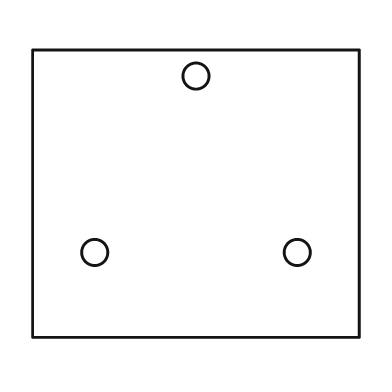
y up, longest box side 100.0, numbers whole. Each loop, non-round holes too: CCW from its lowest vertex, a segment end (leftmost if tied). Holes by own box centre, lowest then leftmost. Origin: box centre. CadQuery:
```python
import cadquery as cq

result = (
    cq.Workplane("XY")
    .moveTo(-50.0, -44.0)
    .lineTo(50.0, -44.0)
    .lineTo(50.0, 44.0)
    .lineTo(-50.0, 44.0)
    .close()
    .moveTo(-31.0, -18.0)
    .circle(4.0)
    .moveTo(31.0, -18.0)
    .circle(4.0)
    .moveTo(0.0, 36.0)
    .circle(4.0)
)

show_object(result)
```